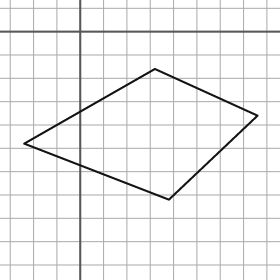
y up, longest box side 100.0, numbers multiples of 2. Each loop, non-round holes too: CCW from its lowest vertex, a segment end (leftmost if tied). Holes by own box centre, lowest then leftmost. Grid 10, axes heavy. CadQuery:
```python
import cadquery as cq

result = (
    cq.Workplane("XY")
    .moveTo(38.0, -72.0)
    .lineTo(76.0, -36.0)
    .lineTo(32.0, -16.0)
    .lineTo(-24.0, -48.0)
    .close()
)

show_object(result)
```